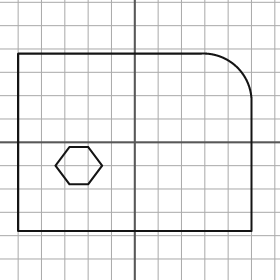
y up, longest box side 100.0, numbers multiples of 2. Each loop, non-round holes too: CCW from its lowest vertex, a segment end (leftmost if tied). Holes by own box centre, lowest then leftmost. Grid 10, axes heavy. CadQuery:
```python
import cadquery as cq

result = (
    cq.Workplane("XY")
    .moveTo(-50.0, -38.0)
    .lineTo(50.0, -38.0)
    .lineTo(50.0, 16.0)
    .threePointArc((44.0, 32.0), (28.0, 38.0))
    .lineTo(-50.0, 38.0)
    .close()
    .moveTo(-28.0, -18.0)
    .lineTo(-20.0, -18.0)
    .lineTo(-14.0, -10.0)
    .lineTo(-20.0, -2.0)
    .lineTo(-28.0, -2.0)
    .lineTo(-34.0, -10.0)
    .close()
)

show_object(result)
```